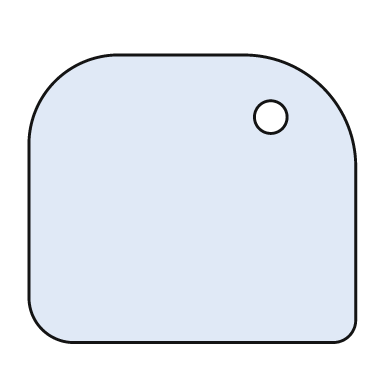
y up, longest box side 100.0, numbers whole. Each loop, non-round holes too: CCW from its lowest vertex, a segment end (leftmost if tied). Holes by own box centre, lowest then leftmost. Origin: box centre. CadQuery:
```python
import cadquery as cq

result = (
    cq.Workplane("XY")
    .moveTo(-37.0, -44.0)
    .lineTo(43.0, -44.0)
    .threePointArc((48.0, -42.0), (50.0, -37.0))
    .lineTo(50.0, 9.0)
    .threePointArc((40.0, 34.0), (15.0, 44.0))
    .lineTo(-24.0, 44.0)
    .threePointArc((-42.0, 36.0), (-50.0, 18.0))
    .lineTo(-50.0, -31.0)
    .threePointArc((-46.0, -40.0), (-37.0, -44.0))
    .close()
    .moveTo(24.0, 25.0)
    .circle(5.0)
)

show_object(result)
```